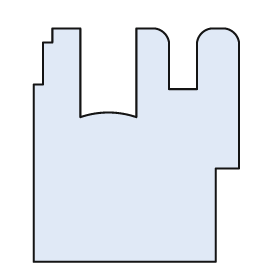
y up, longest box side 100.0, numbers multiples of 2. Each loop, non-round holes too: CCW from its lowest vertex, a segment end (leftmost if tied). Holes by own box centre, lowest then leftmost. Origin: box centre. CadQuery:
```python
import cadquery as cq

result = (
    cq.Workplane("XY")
    .moveTo(-44.0, -50.0)
    .lineTo(34.0, -50.0)
    .lineTo(34.0, -10.0)
    .lineTo(44.0, -10.0)
    .lineTo(44.0, 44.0)
    .threePointArc((42.0, 48.0), (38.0, 50.0))
    .lineTo(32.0, 50.0)
    .threePointArc((28.0, 48.0), (26.0, 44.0))
    .lineTo(26.0, 24.0)
    .lineTo(14.0, 24.0)
    .lineTo(14.0, 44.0)
    .threePointArc((12.0, 48.0), (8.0, 50.0))
    .lineTo(0.0, 50.0)
    .lineTo(0.0, 12.0)
    .threePointArc((-12.0, 14.0), (-24.0, 12.0))
    .lineTo(-24.0, 50.0)
    .lineTo(-36.0, 50.0)
    .lineTo(-36.0, 44.0)
    .lineTo(-40.0, 44.0)
    .lineTo(-40.0, 26.0)
    .lineTo(-44.0, 26.0)
    .close()
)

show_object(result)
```